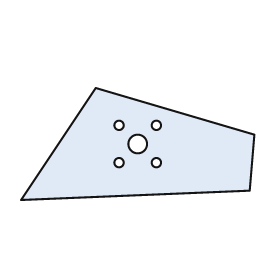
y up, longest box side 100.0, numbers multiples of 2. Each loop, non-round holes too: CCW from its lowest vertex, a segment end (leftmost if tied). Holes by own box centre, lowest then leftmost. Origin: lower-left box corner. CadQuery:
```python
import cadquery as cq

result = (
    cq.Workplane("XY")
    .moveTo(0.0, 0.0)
    .lineTo(98.0, 4.0)
    .lineTo(100.0, 28.0)
    .lineTo(32.0, 48.0)
    .close()
    .moveTo(42.0, 16.0)
    .circle(2.0)
    .moveTo(58.0, 16.0)
    .circle(2.0)
    .moveTo(50.0, 24.0)
    .circle(4.0)
    .moveTo(42.0, 32.0)
    .circle(2.0)
    .moveTo(58.0, 32.0)
    .circle(2.0)
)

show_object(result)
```